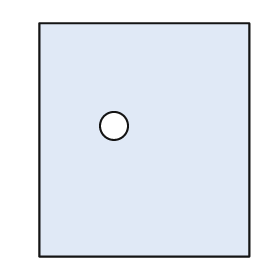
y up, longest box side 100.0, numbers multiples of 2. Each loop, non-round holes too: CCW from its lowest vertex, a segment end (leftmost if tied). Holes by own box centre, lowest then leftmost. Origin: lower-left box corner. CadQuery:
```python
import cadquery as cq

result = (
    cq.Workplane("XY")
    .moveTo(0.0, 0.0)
    .lineTo(90.0, 0.0)
    .lineTo(90.0, 100.0)
    .lineTo(0.0, 100.0)
    .close()
    .moveTo(32.0, 56.0)
    .circle(6.0)
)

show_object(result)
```